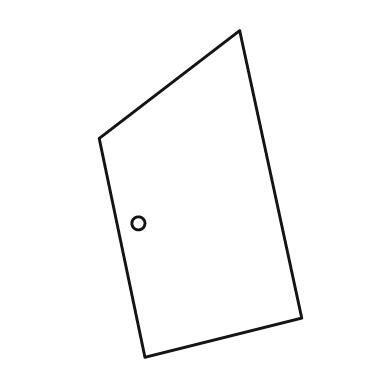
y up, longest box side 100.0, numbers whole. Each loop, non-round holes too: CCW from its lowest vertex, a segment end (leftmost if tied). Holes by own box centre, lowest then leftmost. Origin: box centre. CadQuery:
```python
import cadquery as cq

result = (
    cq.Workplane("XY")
    .moveTo(-17.0, -50.0)
    .lineTo(31.0, -38.0)
    .lineTo(12.0, 50.0)
    .lineTo(-31.0, 17.0)
    .close()
    .moveTo(-19.0, -9.0)
    .circle(2.0)
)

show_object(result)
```